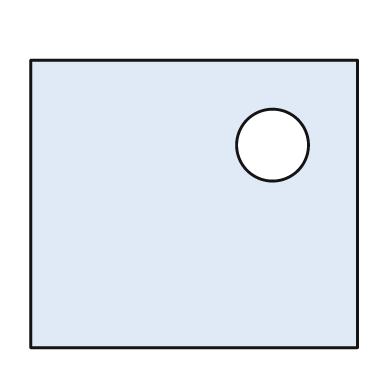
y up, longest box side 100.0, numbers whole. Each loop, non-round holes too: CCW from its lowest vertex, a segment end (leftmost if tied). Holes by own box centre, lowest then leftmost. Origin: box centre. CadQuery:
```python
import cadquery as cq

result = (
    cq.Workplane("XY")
    .moveTo(-50.0, -44.0)
    .lineTo(50.0, -44.0)
    .lineTo(50.0, 44.0)
    .lineTo(-50.0, 44.0)
    .close()
    .moveTo(24.0, 18.0)
    .circle(11.0)
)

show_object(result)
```